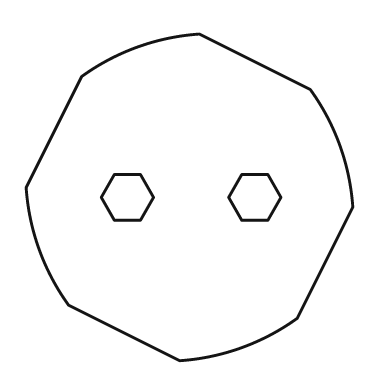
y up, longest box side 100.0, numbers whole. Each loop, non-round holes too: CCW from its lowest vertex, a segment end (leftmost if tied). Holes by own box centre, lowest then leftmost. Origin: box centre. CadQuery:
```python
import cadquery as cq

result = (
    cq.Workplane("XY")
    .moveTo(-3.0, -50.0)
    .threePointArc((16.0, -46.0), (33.0, -37.0))
    .lineTo(50.0, -3.0)
    .threePointArc((46.0, 16.0), (37.0, 33.0))
    .lineTo(3.0, 50.0)
    .threePointArc((-16.0, 46.0), (-33.0, 37.0))
    .lineTo(-50.0, 3.0)
    .threePointArc((-46.0, -16.0), (-37.0, -33.0))
    .close()
    .moveTo(-23.0, -7.0)
    .lineTo(-15.0, -7.0)
    .lineTo(-11.0, 0.0)
    .lineTo(-15.0, 7.0)
    .lineTo(-23.0, 7.0)
    .lineTo(-27.0, 0.0)
    .close()
    .moveTo(16.0, -7.0)
    .lineTo(24.0, -7.0)
    .lineTo(28.0, 0.0)
    .lineTo(24.0, 7.0)
    .lineTo(16.0, 7.0)
    .lineTo(12.0, 0.0)
    .close()
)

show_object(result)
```